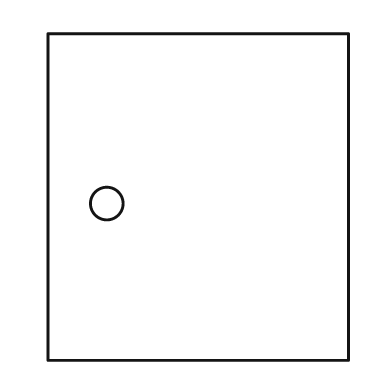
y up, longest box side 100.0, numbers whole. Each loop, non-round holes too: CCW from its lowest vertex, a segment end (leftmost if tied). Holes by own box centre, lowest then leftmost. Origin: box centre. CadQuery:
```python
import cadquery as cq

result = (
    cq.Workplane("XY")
    .moveTo(-46.0, -50.0)
    .lineTo(46.0, -50.0)
    .lineTo(46.0, 50.0)
    .lineTo(-46.0, 50.0)
    .close()
    .moveTo(-28.0, -2.0)
    .circle(5.0)
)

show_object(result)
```